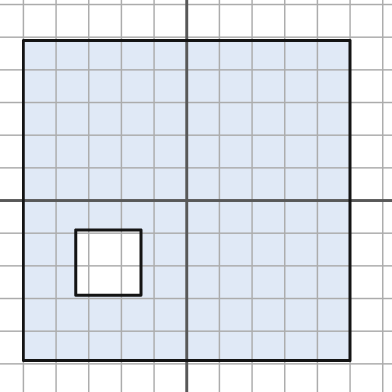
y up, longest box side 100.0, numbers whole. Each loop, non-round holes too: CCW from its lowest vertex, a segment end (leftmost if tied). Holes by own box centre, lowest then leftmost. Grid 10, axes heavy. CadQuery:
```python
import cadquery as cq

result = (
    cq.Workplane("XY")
    .moveTo(-50.0, -49.0)
    .lineTo(50.0, -49.0)
    .lineTo(50.0, 49.0)
    .lineTo(-50.0, 49.0)
    .close()
    .moveTo(-34.0, -29.0)
    .lineTo(-14.0, -29.0)
    .lineTo(-14.0, -9.0)
    .lineTo(-34.0, -9.0)
    .close()
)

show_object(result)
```